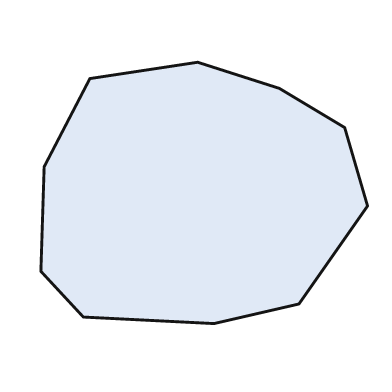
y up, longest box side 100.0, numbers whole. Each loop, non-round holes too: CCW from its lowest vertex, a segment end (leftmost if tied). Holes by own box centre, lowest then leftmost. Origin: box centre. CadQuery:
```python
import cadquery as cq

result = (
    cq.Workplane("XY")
    .moveTo(3.0, -40.0)
    .lineTo(29.0, -34.0)
    .lineTo(50.0, -4.0)
    .lineTo(43.0, 20.0)
    .lineTo(23.0, 32.0)
    .lineTo(-2.0, 40.0)
    .lineTo(-35.0, 35.0)
    .lineTo(-49.0, 8.0)
    .lineTo(-50.0, -24.0)
    .lineTo(-37.0, -38.0)
    .close()
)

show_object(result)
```